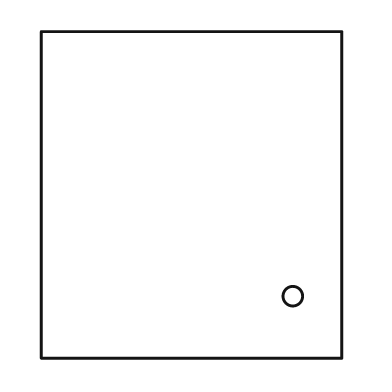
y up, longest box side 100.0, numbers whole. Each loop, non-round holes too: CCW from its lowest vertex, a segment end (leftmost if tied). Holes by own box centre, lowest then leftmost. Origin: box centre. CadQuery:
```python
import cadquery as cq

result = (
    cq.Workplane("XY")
    .moveTo(-46.0, -50.0)
    .lineTo(46.0, -50.0)
    .lineTo(46.0, 50.0)
    .lineTo(-46.0, 50.0)
    .close()
    .moveTo(31.0, -31.0)
    .circle(3.0)
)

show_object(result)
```